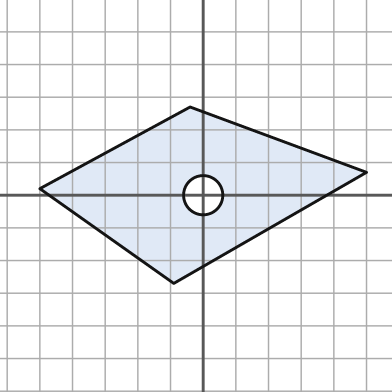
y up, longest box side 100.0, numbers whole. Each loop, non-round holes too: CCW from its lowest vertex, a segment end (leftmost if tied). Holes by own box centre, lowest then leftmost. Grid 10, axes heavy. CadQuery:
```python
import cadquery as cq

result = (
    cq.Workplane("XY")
    .moveTo(-9.0, -27.0)
    .lineTo(50.0, 7.0)
    .lineTo(-4.0, 27.0)
    .lineTo(-50.0, 2.0)
    .close()
    .moveTo(0.0, 0.0)
    .circle(6.0)
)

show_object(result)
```